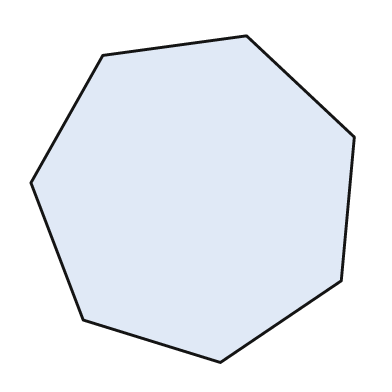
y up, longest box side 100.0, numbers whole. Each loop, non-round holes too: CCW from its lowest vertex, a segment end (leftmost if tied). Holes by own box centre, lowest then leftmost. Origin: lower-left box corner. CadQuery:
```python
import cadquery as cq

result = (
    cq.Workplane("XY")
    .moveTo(58.0, 0.0)
    .lineTo(95.0, 25.0)
    .lineTo(99.0, 69.0)
    .lineTo(66.0, 100.0)
    .lineTo(22.0, 94.0)
    .lineTo(0.0, 55.0)
    .lineTo(16.0, 13.0)
    .close()
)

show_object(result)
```